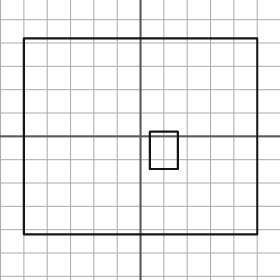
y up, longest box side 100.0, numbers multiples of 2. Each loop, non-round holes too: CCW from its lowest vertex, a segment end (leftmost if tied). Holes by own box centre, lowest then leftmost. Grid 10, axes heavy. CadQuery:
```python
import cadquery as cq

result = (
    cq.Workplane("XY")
    .moveTo(-50.0, -42.0)
    .lineTo(50.0, -42.0)
    .lineTo(50.0, 42.0)
    .lineTo(-50.0, 42.0)
    .close()
    .moveTo(4.0, -14.0)
    .lineTo(16.0, -14.0)
    .lineTo(16.0, 2.0)
    .lineTo(4.0, 2.0)
    .close()
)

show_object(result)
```